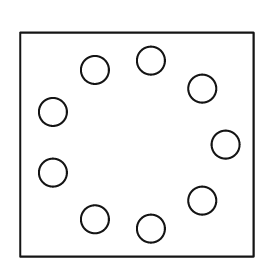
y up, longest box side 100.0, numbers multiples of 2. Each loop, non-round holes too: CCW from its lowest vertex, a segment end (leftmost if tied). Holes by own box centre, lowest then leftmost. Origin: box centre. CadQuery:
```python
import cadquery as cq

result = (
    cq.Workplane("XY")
    .moveTo(-50.0, -48.0)
    .lineTo(50.0, -48.0)
    .lineTo(50.0, 48.0)
    .lineTo(-50.0, 48.0)
    .close()
    .moveTo(6.0, -36.0)
    .circle(6.0)
    .moveTo(-18.0, -32.0)
    .circle(6.0)
    .moveTo(28.0, -24.0)
    .circle(6.0)
    .moveTo(-36.0, -12.0)
    .circle(6.0)
    .moveTo(38.0, 0.0)
    .circle(6.0)
    .moveTo(-36.0, 14.0)
    .circle(6.0)
    .moveTo(28.0, 24.0)
    .circle(6.0)
    .moveTo(-18.0, 32.0)
    .circle(6.0)
    .moveTo(6.0, 36.0)
    .circle(6.0)
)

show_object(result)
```